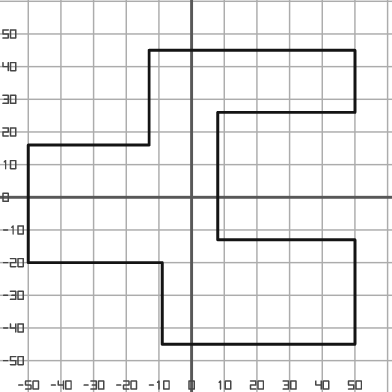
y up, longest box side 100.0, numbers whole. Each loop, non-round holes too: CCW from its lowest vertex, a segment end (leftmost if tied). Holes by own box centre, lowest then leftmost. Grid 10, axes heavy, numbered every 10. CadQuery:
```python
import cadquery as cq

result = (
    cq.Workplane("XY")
    .moveTo(-9.0, -45.0)
    .lineTo(50.0, -45.0)
    .lineTo(50.0, -13.0)
    .lineTo(8.0, -13.0)
    .lineTo(8.0, 26.0)
    .lineTo(50.0, 26.0)
    .lineTo(50.0, 45.0)
    .lineTo(-13.0, 45.0)
    .lineTo(-13.0, 16.0)
    .lineTo(-50.0, 16.0)
    .lineTo(-50.0, -20.0)
    .lineTo(-9.0, -20.0)
    .close()
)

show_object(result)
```